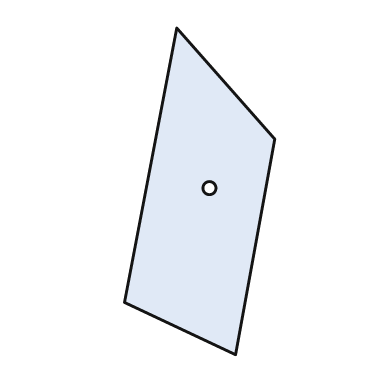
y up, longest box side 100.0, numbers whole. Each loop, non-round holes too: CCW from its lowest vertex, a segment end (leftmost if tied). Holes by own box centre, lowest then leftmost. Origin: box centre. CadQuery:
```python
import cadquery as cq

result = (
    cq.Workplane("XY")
    .moveTo(11.0, -50.0)
    .lineTo(23.0, 16.0)
    .lineTo(-7.0, 50.0)
    .lineTo(-23.0, -34.0)
    .close()
    .moveTo(3.0, 1.0)
    .circle(2.0)
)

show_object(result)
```